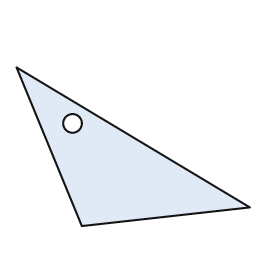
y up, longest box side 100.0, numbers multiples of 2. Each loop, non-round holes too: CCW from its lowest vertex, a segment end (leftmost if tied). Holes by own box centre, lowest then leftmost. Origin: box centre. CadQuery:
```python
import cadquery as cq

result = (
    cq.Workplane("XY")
    .moveTo(-22.0, -34.0)
    .lineTo(50.0, -26.0)
    .lineTo(-50.0, 34.0)
    .close()
    .moveTo(-26.0, 10.0)
    .circle(4.0)
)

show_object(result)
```